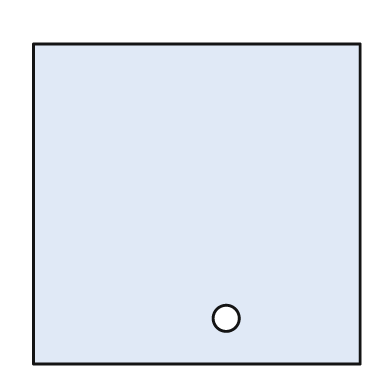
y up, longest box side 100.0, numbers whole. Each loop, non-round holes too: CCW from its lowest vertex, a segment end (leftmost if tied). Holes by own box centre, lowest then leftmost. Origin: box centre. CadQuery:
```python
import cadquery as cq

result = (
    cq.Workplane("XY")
    .moveTo(-50.0, -49.0)
    .lineTo(50.0, -49.0)
    .lineTo(50.0, 49.0)
    .lineTo(-50.0, 49.0)
    .close()
    .moveTo(9.0, -35.0)
    .circle(4.0)
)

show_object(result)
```